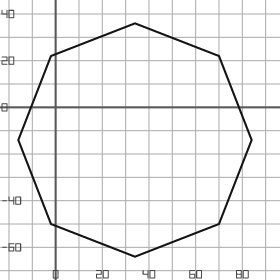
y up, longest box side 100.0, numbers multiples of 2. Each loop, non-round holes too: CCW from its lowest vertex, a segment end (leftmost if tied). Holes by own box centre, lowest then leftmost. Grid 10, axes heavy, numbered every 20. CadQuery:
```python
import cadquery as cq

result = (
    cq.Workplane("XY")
    .moveTo(34.0, -64.0)
    .lineTo(70.0, -50.0)
    .lineTo(84.0, -14.0)
    .lineTo(70.0, 22.0)
    .lineTo(34.0, 36.0)
    .lineTo(-2.0, 22.0)
    .lineTo(-16.0, -14.0)
    .lineTo(-2.0, -50.0)
    .close()
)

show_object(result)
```